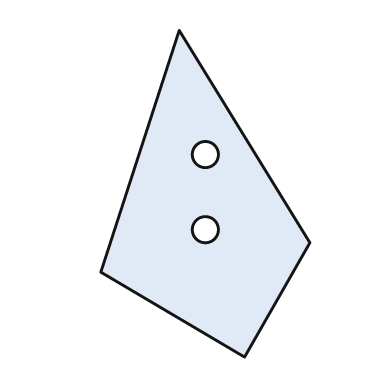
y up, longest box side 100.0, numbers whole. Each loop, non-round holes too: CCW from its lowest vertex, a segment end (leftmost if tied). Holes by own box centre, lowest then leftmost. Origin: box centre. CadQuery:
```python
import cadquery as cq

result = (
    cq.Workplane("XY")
    .moveTo(12.0, -50.0)
    .lineTo(32.0, -15.0)
    .lineTo(-8.0, 50.0)
    .lineTo(-32.0, -24.0)
    .close()
    .moveTo(0.0, -11.0)
    .circle(4.0)
    .moveTo(0.0, 12.0)
    .circle(4.0)
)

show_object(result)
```